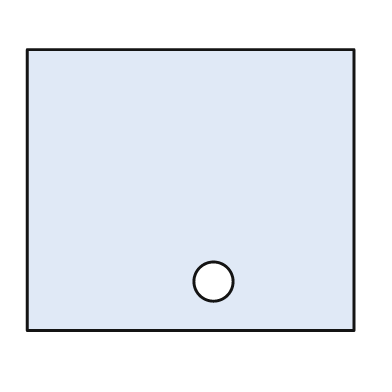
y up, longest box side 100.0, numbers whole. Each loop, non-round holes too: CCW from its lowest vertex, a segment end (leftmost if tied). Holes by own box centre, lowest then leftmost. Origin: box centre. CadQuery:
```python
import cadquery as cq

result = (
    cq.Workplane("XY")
    .moveTo(-50.0, -43.0)
    .lineTo(50.0, -43.0)
    .lineTo(50.0, 43.0)
    .lineTo(-50.0, 43.0)
    .close()
    .moveTo(7.0, -28.0)
    .circle(6.0)
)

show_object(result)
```